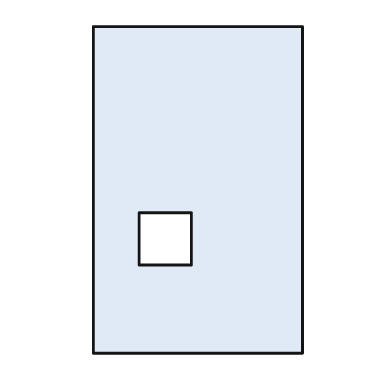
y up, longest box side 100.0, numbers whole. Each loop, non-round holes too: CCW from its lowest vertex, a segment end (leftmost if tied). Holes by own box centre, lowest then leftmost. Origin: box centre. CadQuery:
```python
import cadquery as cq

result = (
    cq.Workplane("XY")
    .moveTo(-32.0, -50.0)
    .lineTo(32.0, -50.0)
    .lineTo(32.0, 50.0)
    .lineTo(-32.0, 50.0)
    .close()
    .moveTo(-18.0, -23.0)
    .lineTo(-2.0, -23.0)
    .lineTo(-2.0, -7.0)
    .lineTo(-18.0, -7.0)
    .close()
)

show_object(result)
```